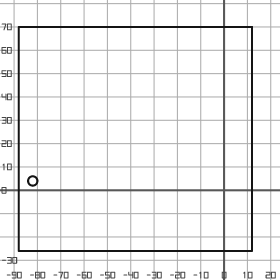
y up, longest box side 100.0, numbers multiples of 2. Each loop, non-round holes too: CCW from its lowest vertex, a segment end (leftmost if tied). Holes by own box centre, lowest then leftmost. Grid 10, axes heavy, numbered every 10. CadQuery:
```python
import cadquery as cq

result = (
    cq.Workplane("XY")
    .moveTo(-88.0, -26.0)
    .lineTo(12.0, -26.0)
    .lineTo(12.0, 70.0)
    .lineTo(-88.0, 70.0)
    .close()
    .moveTo(-82.0, 4.0)
    .circle(2.0)
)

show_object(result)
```